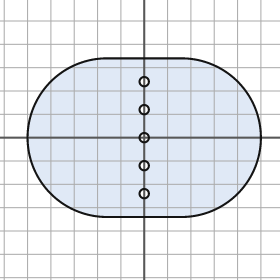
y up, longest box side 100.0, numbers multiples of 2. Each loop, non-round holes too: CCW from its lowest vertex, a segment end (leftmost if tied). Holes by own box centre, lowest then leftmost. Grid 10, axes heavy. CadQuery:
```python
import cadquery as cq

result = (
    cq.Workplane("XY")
    .moveTo(-16.0, -34.0)
    .lineTo(16.0, -34.0)
    .threePointArc((50.0, 0.0), (16.0, 34.0))
    .lineTo(-16.0, 34.0)
    .threePointArc((-50.0, 0.0), (-16.0, -34.0))
    .close()
    .moveTo(0.0, -24.0)
    .circle(2.0)
    .moveTo(0.0, -12.0)
    .circle(2.0)
    .moveTo(0.0, 0.0)
    .circle(2.0)
    .moveTo(0.0, 12.0)
    .circle(2.0)
    .moveTo(0.0, 24.0)
    .circle(2.0)
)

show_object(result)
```